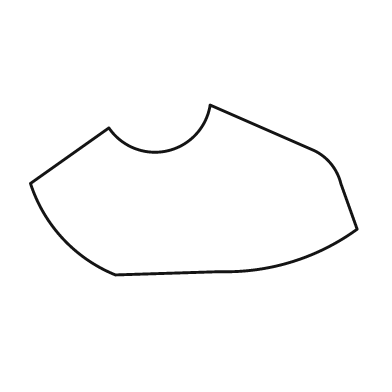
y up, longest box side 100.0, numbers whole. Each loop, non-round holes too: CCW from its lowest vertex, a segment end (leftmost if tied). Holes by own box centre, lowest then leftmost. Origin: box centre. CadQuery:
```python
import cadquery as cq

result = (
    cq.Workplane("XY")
    .moveTo(-24.0, -26.0)
    .lineTo(8.0, -25.0)
    .threePointArc((30.0, -22.0), (50.0, -12.0))
    .lineTo(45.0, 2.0)
    .threePointArc((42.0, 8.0), (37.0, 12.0))
    .lineTo(5.0, 26.0)
    .threePointArc((-8.0, 12.0), (-26.0, 19.0))
    .lineTo(-50.0, 2.0)
    .threePointArc((-40.0, -15.0), (-24.0, -26.0))
    .close()
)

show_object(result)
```